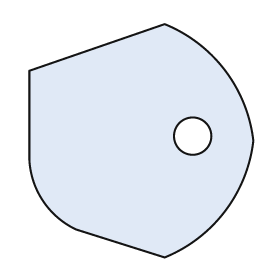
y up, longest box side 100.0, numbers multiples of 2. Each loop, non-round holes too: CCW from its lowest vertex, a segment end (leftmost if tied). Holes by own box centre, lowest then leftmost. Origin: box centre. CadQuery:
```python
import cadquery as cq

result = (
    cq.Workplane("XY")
    .moveTo(10.0, -50.0)
    .threePointArc((36.0, -30.0), (48.0, 0.0))
    .threePointArc((36.0, 30.0), (10.0, 50.0))
    .lineTo(-48.0, 30.0)
    .lineTo(-48.0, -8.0)
    .threePointArc((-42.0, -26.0), (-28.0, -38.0))
    .close()
    .moveTo(22.0, 2.0)
    .circle(8.0)
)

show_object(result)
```